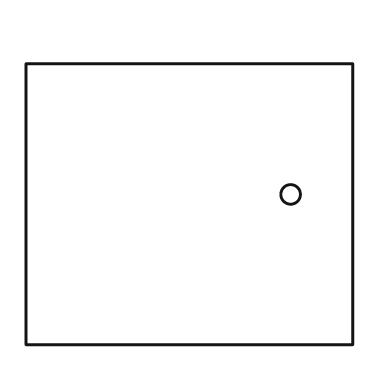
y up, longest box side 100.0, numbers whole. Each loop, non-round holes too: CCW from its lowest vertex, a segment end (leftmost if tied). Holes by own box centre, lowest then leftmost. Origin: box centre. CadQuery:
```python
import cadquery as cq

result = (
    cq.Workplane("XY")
    .moveTo(-50.0, -43.0)
    .lineTo(50.0, -43.0)
    .lineTo(50.0, 43.0)
    .lineTo(-50.0, 43.0)
    .close()
    .moveTo(31.0, 3.0)
    .circle(3.0)
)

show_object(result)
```